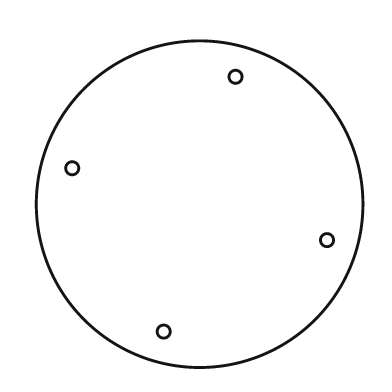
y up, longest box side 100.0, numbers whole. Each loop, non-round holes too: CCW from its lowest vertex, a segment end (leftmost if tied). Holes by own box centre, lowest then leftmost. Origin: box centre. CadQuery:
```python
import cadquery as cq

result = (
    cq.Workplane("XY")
    .moveTo(0.0, 0.0)
    .circle(50.0)
    .moveTo(-11.0, -39.0)
    .circle(2.0)
    .moveTo(39.0, -11.0)
    .circle(2.0)
    .moveTo(-39.0, 11.0)
    .circle(2.0)
    .moveTo(11.0, 39.0)
    .circle(2.0)
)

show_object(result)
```